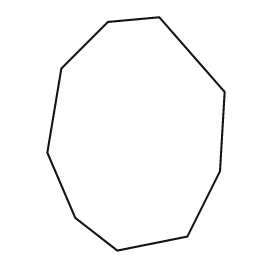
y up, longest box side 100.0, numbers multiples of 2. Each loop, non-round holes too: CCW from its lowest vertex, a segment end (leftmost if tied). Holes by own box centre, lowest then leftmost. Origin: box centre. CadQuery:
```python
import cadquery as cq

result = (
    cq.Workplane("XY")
    .moveTo(-8.0, -50.0)
    .lineTo(22.0, -44.0)
    .lineTo(36.0, -16.0)
    .lineTo(38.0, 18.0)
    .lineTo(10.0, 50.0)
    .lineTo(-12.0, 48.0)
    .lineTo(-32.0, 28.0)
    .lineTo(-38.0, -8.0)
    .lineTo(-26.0, -36.0)
    .close()
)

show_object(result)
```